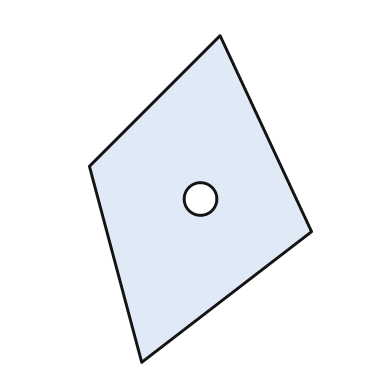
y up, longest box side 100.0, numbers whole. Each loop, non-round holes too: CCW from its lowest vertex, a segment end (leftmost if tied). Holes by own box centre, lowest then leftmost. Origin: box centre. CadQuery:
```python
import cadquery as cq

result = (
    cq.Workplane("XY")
    .moveTo(-18.0, -50.0)
    .lineTo(34.0, -10.0)
    .lineTo(6.0, 50.0)
    .lineTo(-34.0, 10.0)
    .close()
    .moveTo(0.0, 0.0)
    .circle(5.0)
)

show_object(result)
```